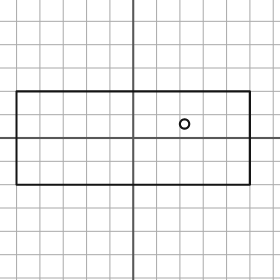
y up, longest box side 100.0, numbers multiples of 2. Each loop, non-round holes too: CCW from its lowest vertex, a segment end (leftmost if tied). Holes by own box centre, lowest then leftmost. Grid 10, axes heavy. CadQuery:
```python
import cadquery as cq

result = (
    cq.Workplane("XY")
    .moveTo(-50.0, -20.0)
    .lineTo(50.0, -20.0)
    .lineTo(50.0, 20.0)
    .lineTo(-50.0, 20.0)
    .close()
    .moveTo(22.0, 6.0)
    .circle(2.0)
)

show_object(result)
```